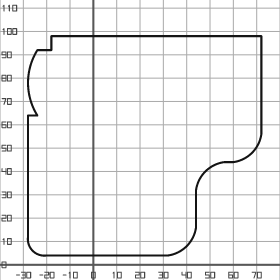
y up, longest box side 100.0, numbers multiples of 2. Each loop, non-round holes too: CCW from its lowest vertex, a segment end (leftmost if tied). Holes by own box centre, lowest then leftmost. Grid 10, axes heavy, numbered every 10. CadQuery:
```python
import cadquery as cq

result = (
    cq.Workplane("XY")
    .moveTo(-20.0, 4.0)
    .lineTo(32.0, 4.0)
    .threePointArc((40.0, 8.0), (44.0, 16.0))
    .lineTo(44.0, 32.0)
    .threePointArc((48.0, 40.0), (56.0, 44.0))
    .lineTo(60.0, 44.0)
    .threePointArc((68.0, 48.0), (72.0, 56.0))
    .lineTo(72.0, 98.0)
    .lineTo(-18.0, 98.0)
    .lineTo(-18.0, 92.0)
    .lineTo(-24.0, 92.0)
    .threePointArc((-28.0, 78.0), (-24.0, 64.0))
    .lineTo(-28.0, 64.0)
    .lineTo(-28.0, 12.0)
    .threePointArc((-26.0, 6.0), (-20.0, 4.0))
    .close()
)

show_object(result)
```